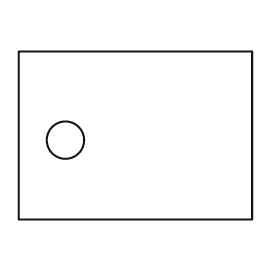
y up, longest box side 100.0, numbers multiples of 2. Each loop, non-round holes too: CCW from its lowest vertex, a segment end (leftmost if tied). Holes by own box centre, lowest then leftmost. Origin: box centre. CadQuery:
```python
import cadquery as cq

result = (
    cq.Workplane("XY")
    .moveTo(-50.0, -36.0)
    .lineTo(50.0, -36.0)
    .lineTo(50.0, 36.0)
    .lineTo(-50.0, 36.0)
    .close()
    .moveTo(-30.0, -2.0)
    .circle(8.0)
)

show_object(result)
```